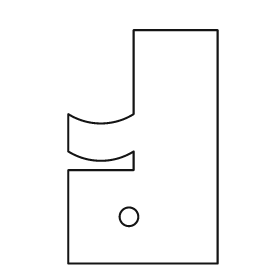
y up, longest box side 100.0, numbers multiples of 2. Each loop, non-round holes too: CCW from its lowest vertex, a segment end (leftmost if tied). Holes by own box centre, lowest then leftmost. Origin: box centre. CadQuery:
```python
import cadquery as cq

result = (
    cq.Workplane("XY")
    .moveTo(-32.0, -50.0)
    .lineTo(32.0, -50.0)
    .lineTo(32.0, 50.0)
    .lineTo(-4.0, 50.0)
    .lineTo(-4.0, 14.0)
    .threePointArc((-18.0, 10.0), (-32.0, 14.0))
    .lineTo(-32.0, -2.0)
    .threePointArc((-18.0, -6.0), (-4.0, -2.0))
    .lineTo(-4.0, -10.0)
    .lineTo(-32.0, -10.0)
    .close()
    .moveTo(-6.0, -30.0)
    .circle(4.0)
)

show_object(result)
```